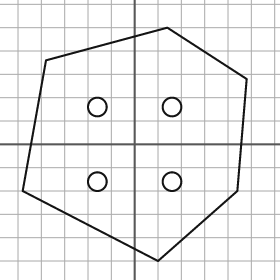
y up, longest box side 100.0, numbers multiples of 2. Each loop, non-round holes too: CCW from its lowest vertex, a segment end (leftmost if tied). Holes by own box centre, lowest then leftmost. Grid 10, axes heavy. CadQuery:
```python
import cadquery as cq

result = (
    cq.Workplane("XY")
    .moveTo(10.0, -50.0)
    .lineTo(44.0, -20.0)
    .lineTo(48.0, 28.0)
    .lineTo(14.0, 50.0)
    .lineTo(-38.0, 36.0)
    .lineTo(-48.0, -20.0)
    .close()
    .moveTo(-16.0, -16.0)
    .circle(4.0)
    .moveTo(16.0, -16.0)
    .circle(4.0)
    .moveTo(-16.0, 16.0)
    .circle(4.0)
    .moveTo(16.0, 16.0)
    .circle(4.0)
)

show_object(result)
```